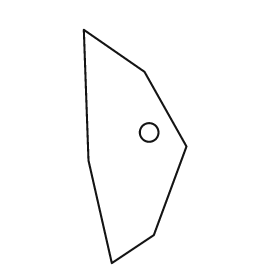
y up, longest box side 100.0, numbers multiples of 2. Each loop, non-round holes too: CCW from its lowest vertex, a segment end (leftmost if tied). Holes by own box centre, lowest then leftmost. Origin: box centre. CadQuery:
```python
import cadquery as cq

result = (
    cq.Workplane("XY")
    .moveTo(-10.0, -50.0)
    .lineTo(8.0, -38.0)
    .lineTo(22.0, 0.0)
    .lineTo(4.0, 32.0)
    .lineTo(-22.0, 50.0)
    .lineTo(-20.0, -6.0)
    .close()
    .moveTo(6.0, 6.0)
    .circle(4.0)
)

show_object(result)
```